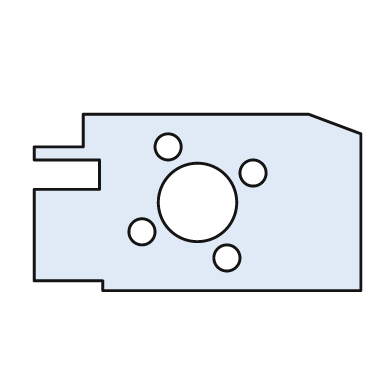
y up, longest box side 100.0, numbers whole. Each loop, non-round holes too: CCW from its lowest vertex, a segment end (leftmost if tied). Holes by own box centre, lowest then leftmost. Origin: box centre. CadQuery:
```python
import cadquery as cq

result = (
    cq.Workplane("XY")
    .moveTo(-29.0, -27.0)
    .lineTo(50.0, -27.0)
    .lineTo(50.0, 21.0)
    .lineTo(34.0, 27.0)
    .lineTo(-35.0, 27.0)
    .lineTo(-35.0, 17.0)
    .lineTo(-50.0, 17.0)
    .lineTo(-50.0, 13.0)
    .lineTo(-30.0, 13.0)
    .lineTo(-30.0, 4.0)
    .lineTo(-50.0, 4.0)
    .lineTo(-50.0, -24.0)
    .lineTo(-29.0, -24.0)
    .close()
    .moveTo(9.0, -17.0)
    .circle(4.0)
    .moveTo(-17.0, -9.0)
    .circle(4.0)
    .moveTo(0.0, 0.0)
    .circle(12.0)
    .moveTo(17.0, 9.0)
    .circle(4.0)
    .moveTo(-9.0, 17.0)
    .circle(4.0)
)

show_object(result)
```